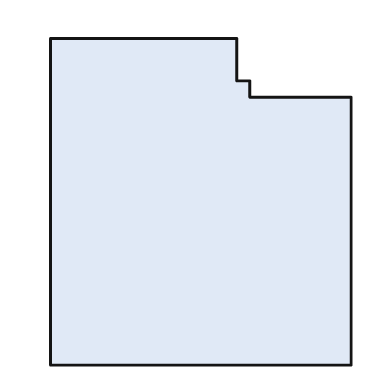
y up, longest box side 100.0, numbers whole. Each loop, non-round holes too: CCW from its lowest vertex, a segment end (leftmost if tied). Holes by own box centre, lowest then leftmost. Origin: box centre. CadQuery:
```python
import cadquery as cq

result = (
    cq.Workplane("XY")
    .moveTo(-46.0, -50.0)
    .lineTo(46.0, -50.0)
    .lineTo(46.0, 32.0)
    .lineTo(15.0, 32.0)
    .lineTo(15.0, 37.0)
    .lineTo(11.0, 37.0)
    .lineTo(11.0, 50.0)
    .lineTo(-46.0, 50.0)
    .close()
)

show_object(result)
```